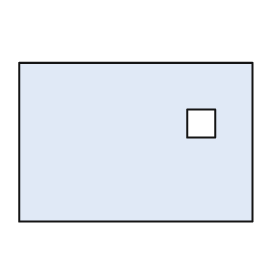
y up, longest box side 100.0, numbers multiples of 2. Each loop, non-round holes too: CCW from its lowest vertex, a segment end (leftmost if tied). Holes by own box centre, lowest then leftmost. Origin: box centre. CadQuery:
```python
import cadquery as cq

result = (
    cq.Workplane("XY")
    .moveTo(-50.0, -34.0)
    .lineTo(50.0, -34.0)
    .lineTo(50.0, 34.0)
    .lineTo(-50.0, 34.0)
    .close()
    .moveTo(22.0, 2.0)
    .lineTo(34.0, 2.0)
    .lineTo(34.0, 14.0)
    .lineTo(22.0, 14.0)
    .close()
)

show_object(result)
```